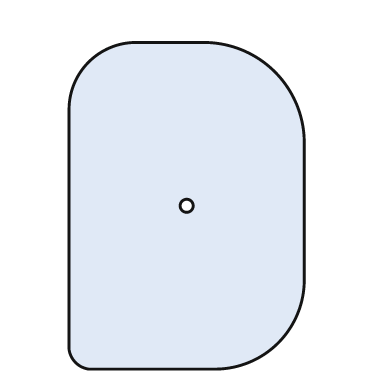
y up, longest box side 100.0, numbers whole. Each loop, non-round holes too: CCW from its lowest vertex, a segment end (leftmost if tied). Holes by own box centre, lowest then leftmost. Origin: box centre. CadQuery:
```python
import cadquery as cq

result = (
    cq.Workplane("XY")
    .moveTo(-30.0, -50.0)
    .lineTo(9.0, -50.0)
    .threePointArc((28.0, -42.0), (36.0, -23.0))
    .lineTo(36.0, 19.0)
    .threePointArc((27.0, 41.0), (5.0, 50.0))
    .lineTo(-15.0, 50.0)
    .threePointArc((-30.0, 44.0), (-36.0, 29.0))
    .lineTo(-36.0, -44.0)
    .threePointArc((-34.0, -48.0), (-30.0, -50.0))
    .close()
    .moveTo(0.0, 0.0)
    .circle(2.0)
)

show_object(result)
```